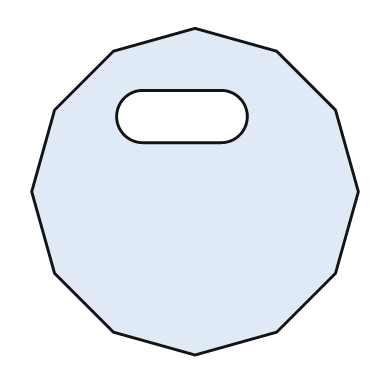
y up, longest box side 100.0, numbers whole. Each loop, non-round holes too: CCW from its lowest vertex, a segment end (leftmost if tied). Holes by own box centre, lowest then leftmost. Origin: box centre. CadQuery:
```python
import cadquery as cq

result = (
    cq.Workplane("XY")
    .moveTo(0.0, -50.0)
    .lineTo(25.0, -43.0)
    .lineTo(43.0, -25.0)
    .lineTo(50.0, 0.0)
    .lineTo(43.0, 25.0)
    .lineTo(25.0, 43.0)
    .lineTo(0.0, 50.0)
    .lineTo(-25.0, 43.0)
    .lineTo(-43.0, 25.0)
    .lineTo(-50.0, 0.0)
    .lineTo(-43.0, -25.0)
    .lineTo(-25.0, -43.0)
    .close()
    .moveTo(-16.0, 15.0)
    .lineTo(8.0, 15.0)
    .threePointArc((16.0, 23.0), (8.0, 31.0))
    .lineTo(-16.0, 31.0)
    .threePointArc((-24.0, 23.0), (-16.0, 15.0))
    .close()
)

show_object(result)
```